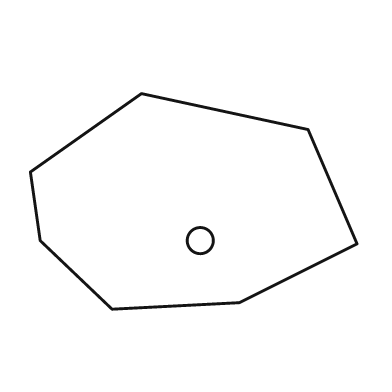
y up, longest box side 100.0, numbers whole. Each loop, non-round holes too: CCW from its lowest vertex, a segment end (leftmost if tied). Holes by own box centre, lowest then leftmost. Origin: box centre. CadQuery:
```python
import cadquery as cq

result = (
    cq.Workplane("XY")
    .moveTo(-25.0, -33.0)
    .lineTo(14.0, -31.0)
    .lineTo(50.0, -13.0)
    .lineTo(35.0, 22.0)
    .lineTo(-16.0, 33.0)
    .lineTo(-50.0, 9.0)
    .lineTo(-47.0, -12.0)
    .close()
    .moveTo(2.0, -12.0)
    .circle(4.0)
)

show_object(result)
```